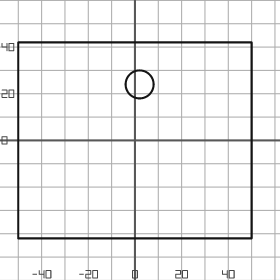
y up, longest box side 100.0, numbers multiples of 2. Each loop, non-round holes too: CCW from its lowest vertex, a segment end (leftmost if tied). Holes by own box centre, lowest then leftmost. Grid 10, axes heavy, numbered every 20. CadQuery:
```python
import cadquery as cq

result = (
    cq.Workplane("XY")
    .moveTo(-50.0, -42.0)
    .lineTo(50.0, -42.0)
    .lineTo(50.0, 42.0)
    .lineTo(-50.0, 42.0)
    .close()
    .moveTo(2.0, 24.0)
    .circle(6.0)
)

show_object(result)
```